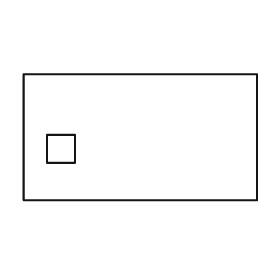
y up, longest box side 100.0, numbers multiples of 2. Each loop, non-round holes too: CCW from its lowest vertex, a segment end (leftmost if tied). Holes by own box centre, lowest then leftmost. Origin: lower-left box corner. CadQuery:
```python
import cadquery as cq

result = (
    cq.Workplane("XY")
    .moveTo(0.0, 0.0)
    .lineTo(100.0, 0.0)
    .lineTo(100.0, 54.0)
    .lineTo(0.0, 54.0)
    .close()
    .moveTo(10.0, 16.0)
    .lineTo(22.0, 16.0)
    .lineTo(22.0, 28.0)
    .lineTo(10.0, 28.0)
    .close()
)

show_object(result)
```